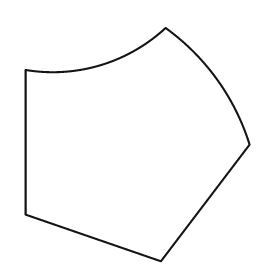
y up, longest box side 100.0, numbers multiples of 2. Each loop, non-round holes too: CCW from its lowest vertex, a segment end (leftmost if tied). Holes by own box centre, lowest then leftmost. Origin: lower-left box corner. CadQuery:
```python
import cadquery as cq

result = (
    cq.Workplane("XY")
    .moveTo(58.0, 0.0)
    .lineTo(96.0, 50.0)
    .threePointArc((82.0, 78.0), (60.0, 100.0))
    .threePointArc((32.0, 84.0), (0.0, 82.0))
    .lineTo(0.0, 20.0)
    .close()
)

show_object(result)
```